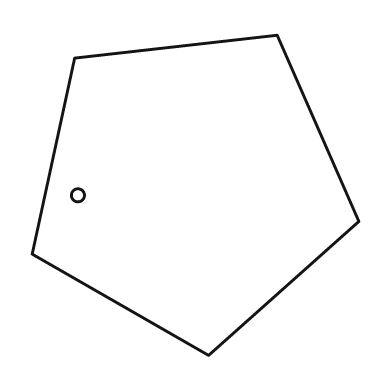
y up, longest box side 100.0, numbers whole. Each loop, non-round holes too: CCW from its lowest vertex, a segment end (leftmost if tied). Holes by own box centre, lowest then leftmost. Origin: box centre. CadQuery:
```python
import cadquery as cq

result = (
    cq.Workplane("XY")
    .moveTo(4.0, -49.0)
    .lineTo(50.0, -8.0)
    .lineTo(25.0, 49.0)
    .lineTo(-37.0, 42.0)
    .lineTo(-50.0, -18.0)
    .close()
    .moveTo(-36.0, 0.0)
    .circle(2.0)
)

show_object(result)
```